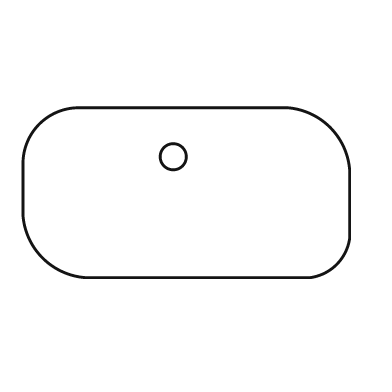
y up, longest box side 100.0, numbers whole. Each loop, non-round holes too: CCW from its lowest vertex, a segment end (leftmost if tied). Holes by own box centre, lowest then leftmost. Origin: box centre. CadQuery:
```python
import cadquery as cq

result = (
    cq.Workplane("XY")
    .moveTo(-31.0, -26.0)
    .lineTo(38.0, -26.0)
    .threePointArc((46.0, -22.0), (50.0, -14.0))
    .lineTo(50.0, 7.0)
    .threePointArc((44.0, 20.0), (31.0, 26.0))
    .lineTo(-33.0, 26.0)
    .threePointArc((-45.0, 21.0), (-50.0, 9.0))
    .lineTo(-50.0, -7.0)
    .threePointArc((-44.0, -20.0), (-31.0, -26.0))
    .close()
    .moveTo(-4.0, 11.0)
    .circle(4.0)
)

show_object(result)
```